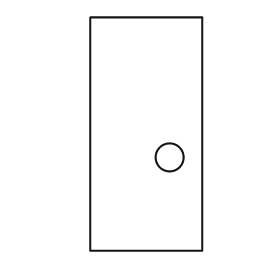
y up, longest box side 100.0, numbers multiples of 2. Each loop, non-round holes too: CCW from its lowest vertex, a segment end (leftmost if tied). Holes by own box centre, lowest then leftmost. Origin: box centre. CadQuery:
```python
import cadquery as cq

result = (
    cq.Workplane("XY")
    .moveTo(-24.0, -50.0)
    .lineTo(24.0, -50.0)
    .lineTo(24.0, 50.0)
    .lineTo(-24.0, 50.0)
    .close()
    .moveTo(10.0, -10.0)
    .circle(6.0)
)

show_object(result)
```